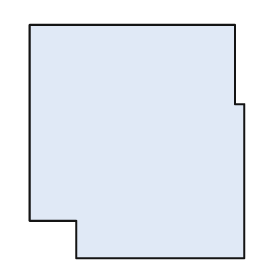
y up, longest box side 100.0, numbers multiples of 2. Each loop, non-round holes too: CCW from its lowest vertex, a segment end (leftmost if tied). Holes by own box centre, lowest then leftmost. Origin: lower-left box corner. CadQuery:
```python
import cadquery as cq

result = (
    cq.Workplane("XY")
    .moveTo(20.0, 0.0)
    .lineTo(92.0, 0.0)
    .lineTo(92.0, 66.0)
    .lineTo(88.0, 66.0)
    .lineTo(88.0, 100.0)
    .lineTo(0.0, 100.0)
    .lineTo(0.0, 16.0)
    .lineTo(20.0, 16.0)
    .close()
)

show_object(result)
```